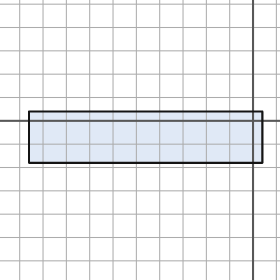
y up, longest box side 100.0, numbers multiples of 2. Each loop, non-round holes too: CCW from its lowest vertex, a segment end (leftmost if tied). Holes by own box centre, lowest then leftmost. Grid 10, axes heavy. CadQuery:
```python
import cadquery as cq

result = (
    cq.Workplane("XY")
    .moveTo(-96.0, -18.0)
    .lineTo(4.0, -18.0)
    .lineTo(4.0, 4.0)
    .lineTo(-96.0, 4.0)
    .close()
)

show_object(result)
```